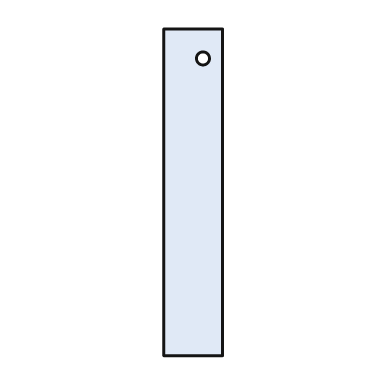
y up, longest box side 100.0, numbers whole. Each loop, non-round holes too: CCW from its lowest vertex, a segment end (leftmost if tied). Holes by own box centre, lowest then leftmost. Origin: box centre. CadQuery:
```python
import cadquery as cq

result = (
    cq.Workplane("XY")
    .moveTo(-9.0, -50.0)
    .lineTo(9.0, -50.0)
    .lineTo(9.0, 50.0)
    .lineTo(-9.0, 50.0)
    .close()
    .moveTo(3.0, 41.0)
    .circle(2.0)
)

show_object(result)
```